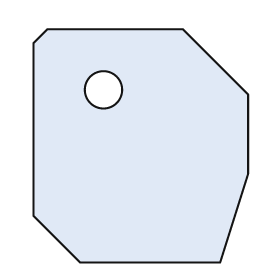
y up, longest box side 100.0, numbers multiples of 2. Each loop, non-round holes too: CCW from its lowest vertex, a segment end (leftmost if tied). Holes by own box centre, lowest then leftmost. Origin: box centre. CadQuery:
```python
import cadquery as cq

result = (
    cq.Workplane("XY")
    .moveTo(-26.0, -50.0)
    .lineTo(34.0, -50.0)
    .lineTo(46.0, -12.0)
    .lineTo(46.0, 22.0)
    .lineTo(18.0, 50.0)
    .lineTo(-40.0, 50.0)
    .lineTo(-46.0, 44.0)
    .lineTo(-46.0, -30.0)
    .close()
    .moveTo(-16.0, 24.0)
    .circle(8.0)
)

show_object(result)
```